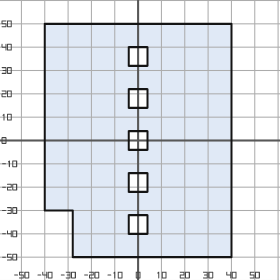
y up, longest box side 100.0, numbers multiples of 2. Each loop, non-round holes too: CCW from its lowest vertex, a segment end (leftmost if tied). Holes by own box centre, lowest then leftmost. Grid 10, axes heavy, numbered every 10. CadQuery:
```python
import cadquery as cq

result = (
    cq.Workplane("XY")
    .moveTo(-28.0, -50.0)
    .lineTo(40.0, -50.0)
    .lineTo(40.0, 50.0)
    .lineTo(-40.0, 50.0)
    .lineTo(-40.0, -30.0)
    .lineTo(-28.0, -30.0)
    .close()
    .moveTo(-4.0, -40.0)
    .lineTo(4.0, -40.0)
    .lineTo(4.0, -32.0)
    .lineTo(-4.0, -32.0)
    .close()
    .moveTo(-4.0, -22.0)
    .lineTo(4.0, -22.0)
    .lineTo(4.0, -14.0)
    .lineTo(-4.0, -14.0)
    .close()
    .moveTo(-4.0, -4.0)
    .lineTo(4.0, -4.0)
    .lineTo(4.0, 4.0)
    .lineTo(-4.0, 4.0)
    .close()
    .moveTo(-4.0, 14.0)
    .lineTo(4.0, 14.0)
    .lineTo(4.0, 22.0)
    .lineTo(-4.0, 22.0)
    .close()
    .moveTo(-4.0, 32.0)
    .lineTo(4.0, 32.0)
    .lineTo(4.0, 40.0)
    .lineTo(-4.0, 40.0)
    .close()
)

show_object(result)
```